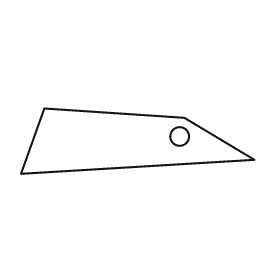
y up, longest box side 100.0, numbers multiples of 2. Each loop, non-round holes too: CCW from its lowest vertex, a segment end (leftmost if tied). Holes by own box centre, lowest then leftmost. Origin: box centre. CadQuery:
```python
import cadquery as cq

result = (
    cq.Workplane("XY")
    .moveTo(-50.0, -14.0)
    .lineTo(50.0, -8.0)
    .lineTo(20.0, 10.0)
    .lineTo(-40.0, 14.0)
    .close()
    .moveTo(18.0, 2.0)
    .circle(4.0)
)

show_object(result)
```